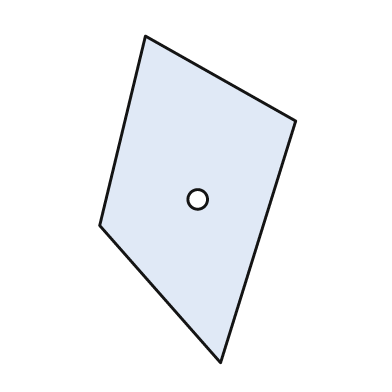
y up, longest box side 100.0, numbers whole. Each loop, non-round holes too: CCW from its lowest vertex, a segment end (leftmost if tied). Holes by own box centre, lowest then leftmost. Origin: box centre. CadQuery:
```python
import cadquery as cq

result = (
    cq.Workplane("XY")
    .moveTo(7.0, -50.0)
    .lineTo(30.0, 24.0)
    .lineTo(-16.0, 50.0)
    .lineTo(-30.0, -8.0)
    .close()
    .moveTo(0.0, 0.0)
    .circle(3.0)
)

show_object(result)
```